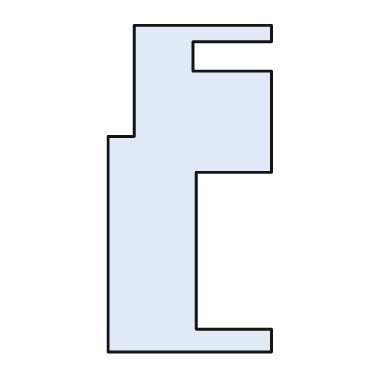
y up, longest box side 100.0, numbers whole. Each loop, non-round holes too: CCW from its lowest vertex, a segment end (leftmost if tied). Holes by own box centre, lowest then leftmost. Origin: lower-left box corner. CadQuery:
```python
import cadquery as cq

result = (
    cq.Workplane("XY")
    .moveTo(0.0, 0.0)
    .lineTo(50.0, 0.0)
    .lineTo(50.0, 7.0)
    .lineTo(27.0, 7.0)
    .lineTo(27.0, 55.0)
    .lineTo(50.0, 55.0)
    .lineTo(50.0, 86.0)
    .lineTo(26.0, 86.0)
    .lineTo(26.0, 95.0)
    .lineTo(50.0, 95.0)
    .lineTo(50.0, 100.0)
    .lineTo(8.0, 100.0)
    .lineTo(8.0, 66.0)
    .lineTo(0.0, 66.0)
    .close()
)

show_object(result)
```